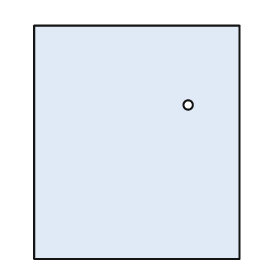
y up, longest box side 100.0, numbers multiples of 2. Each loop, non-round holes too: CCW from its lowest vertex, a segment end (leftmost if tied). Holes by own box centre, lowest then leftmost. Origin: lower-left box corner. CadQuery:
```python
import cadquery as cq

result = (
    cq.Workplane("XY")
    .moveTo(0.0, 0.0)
    .lineTo(88.0, 0.0)
    .lineTo(88.0, 100.0)
    .lineTo(0.0, 100.0)
    .close()
    .moveTo(66.0, 66.0)
    .circle(2.0)
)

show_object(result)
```